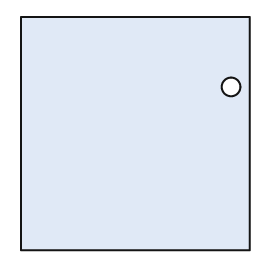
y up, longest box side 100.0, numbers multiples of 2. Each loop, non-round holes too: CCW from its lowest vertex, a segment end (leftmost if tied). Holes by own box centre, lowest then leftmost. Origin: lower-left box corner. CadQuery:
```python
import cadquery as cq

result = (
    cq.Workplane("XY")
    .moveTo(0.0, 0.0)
    .lineTo(98.0, 0.0)
    .lineTo(98.0, 100.0)
    .lineTo(0.0, 100.0)
    .close()
    .moveTo(90.0, 70.0)
    .circle(4.0)
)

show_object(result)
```